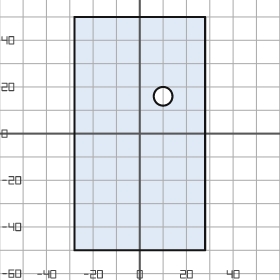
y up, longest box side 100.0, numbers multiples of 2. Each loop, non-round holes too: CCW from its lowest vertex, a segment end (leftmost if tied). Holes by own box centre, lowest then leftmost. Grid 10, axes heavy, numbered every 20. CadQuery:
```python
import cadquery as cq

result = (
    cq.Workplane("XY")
    .moveTo(-28.0, -50.0)
    .lineTo(28.0, -50.0)
    .lineTo(28.0, 50.0)
    .lineTo(-28.0, 50.0)
    .close()
    .moveTo(10.0, 16.0)
    .circle(4.0)
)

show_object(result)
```